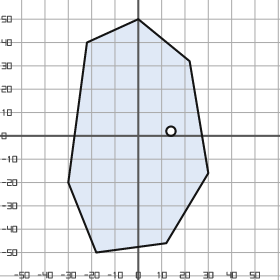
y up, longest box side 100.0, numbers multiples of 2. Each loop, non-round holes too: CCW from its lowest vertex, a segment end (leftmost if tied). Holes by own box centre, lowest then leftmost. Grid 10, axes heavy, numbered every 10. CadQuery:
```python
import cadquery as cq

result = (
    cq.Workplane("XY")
    .moveTo(-18.0, -50.0)
    .lineTo(12.0, -46.0)
    .lineTo(30.0, -16.0)
    .lineTo(22.0, 32.0)
    .lineTo(0.0, 50.0)
    .lineTo(-22.0, 40.0)
    .lineTo(-30.0, -20.0)
    .close()
    .moveTo(14.0, 2.0)
    .circle(2.0)
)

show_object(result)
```